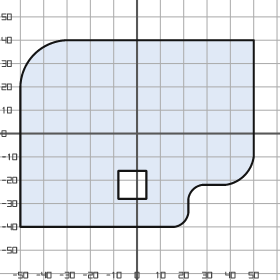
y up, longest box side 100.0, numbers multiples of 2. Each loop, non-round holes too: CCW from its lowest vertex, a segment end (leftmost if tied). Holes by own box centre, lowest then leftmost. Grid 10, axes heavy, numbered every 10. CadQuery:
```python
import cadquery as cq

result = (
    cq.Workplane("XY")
    .moveTo(-50.0, -40.0)
    .lineTo(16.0, -40.0)
    .threePointArc((20.0, -38.0), (22.0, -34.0))
    .lineTo(22.0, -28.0)
    .threePointArc((24.0, -24.0), (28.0, -22.0))
    .lineTo(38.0, -22.0)
    .threePointArc((46.0, -18.0), (50.0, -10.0))
    .lineTo(50.0, 40.0)
    .lineTo(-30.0, 40.0)
    .threePointArc((-44.0, 34.0), (-50.0, 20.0))
    .close()
    .moveTo(-8.0, -28.0)
    .lineTo(4.0, -28.0)
    .lineTo(4.0, -16.0)
    .lineTo(-8.0, -16.0)
    .close()
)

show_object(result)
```